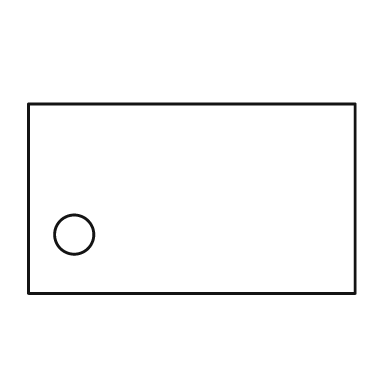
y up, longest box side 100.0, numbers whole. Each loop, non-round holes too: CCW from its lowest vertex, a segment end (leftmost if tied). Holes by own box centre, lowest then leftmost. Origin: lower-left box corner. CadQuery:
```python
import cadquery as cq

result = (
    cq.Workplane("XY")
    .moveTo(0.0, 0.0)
    .lineTo(100.0, 0.0)
    .lineTo(100.0, 58.0)
    .lineTo(0.0, 58.0)
    .close()
    .moveTo(14.0, 18.0)
    .circle(6.0)
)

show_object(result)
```